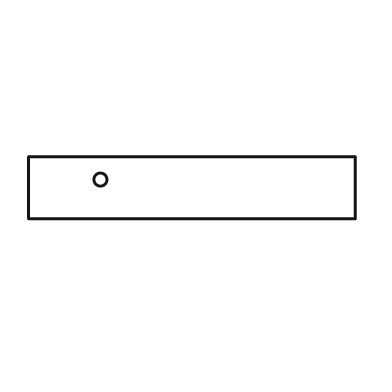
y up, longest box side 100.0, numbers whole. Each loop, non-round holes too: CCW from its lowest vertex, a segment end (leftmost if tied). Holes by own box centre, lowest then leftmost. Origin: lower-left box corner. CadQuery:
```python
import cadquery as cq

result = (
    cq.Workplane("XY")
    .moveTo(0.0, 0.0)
    .lineTo(100.0, 0.0)
    .lineTo(100.0, 19.0)
    .lineTo(0.0, 19.0)
    .close()
    .moveTo(22.0, 12.0)
    .circle(2.0)
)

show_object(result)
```